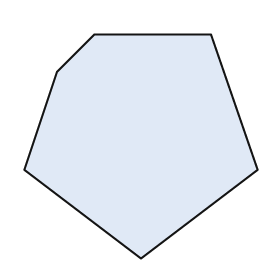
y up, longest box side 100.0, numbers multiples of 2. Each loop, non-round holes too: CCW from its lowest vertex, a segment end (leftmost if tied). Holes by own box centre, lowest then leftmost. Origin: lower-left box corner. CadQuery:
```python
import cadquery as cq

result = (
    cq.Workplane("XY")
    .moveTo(50.0, 0.0)
    .lineTo(100.0, 38.0)
    .lineTo(80.0, 96.0)
    .lineTo(30.0, 96.0)
    .lineTo(14.0, 80.0)
    .lineTo(0.0, 38.0)
    .close()
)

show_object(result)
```